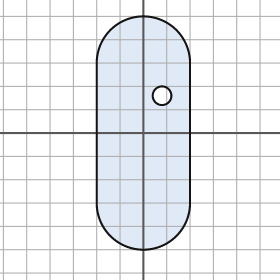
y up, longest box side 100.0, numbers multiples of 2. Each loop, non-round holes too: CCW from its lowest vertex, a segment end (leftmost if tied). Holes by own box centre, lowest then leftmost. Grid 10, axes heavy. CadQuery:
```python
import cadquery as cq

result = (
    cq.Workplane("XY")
    .moveTo(-20.0, -30.0)
    .threePointArc((0.0, -50.0), (20.0, -30.0))
    .lineTo(20.0, 30.0)
    .threePointArc((0.0, 50.0), (-20.0, 30.0))
    .close()
    .moveTo(8.0, 16.0)
    .circle(4.0)
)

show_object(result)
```